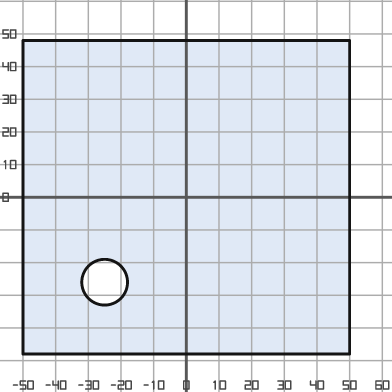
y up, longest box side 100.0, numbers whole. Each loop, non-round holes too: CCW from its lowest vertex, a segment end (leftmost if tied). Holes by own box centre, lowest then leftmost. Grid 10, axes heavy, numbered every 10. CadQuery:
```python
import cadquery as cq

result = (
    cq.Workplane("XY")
    .moveTo(-50.0, -48.0)
    .lineTo(50.0, -48.0)
    .lineTo(50.0, 48.0)
    .lineTo(-50.0, 48.0)
    .close()
    .moveTo(-25.0, -26.0)
    .circle(7.0)
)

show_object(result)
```